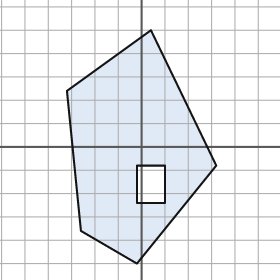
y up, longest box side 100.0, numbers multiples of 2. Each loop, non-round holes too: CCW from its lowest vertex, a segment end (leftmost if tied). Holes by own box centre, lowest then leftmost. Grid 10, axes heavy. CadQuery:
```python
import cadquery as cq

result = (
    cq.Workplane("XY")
    .moveTo(-2.0, -50.0)
    .lineTo(32.0, -8.0)
    .lineTo(4.0, 50.0)
    .lineTo(-32.0, 24.0)
    .lineTo(-26.0, -36.0)
    .close()
    .moveTo(-2.0, -24.0)
    .lineTo(10.0, -24.0)
    .lineTo(10.0, -8.0)
    .lineTo(-2.0, -8.0)
    .close()
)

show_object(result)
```